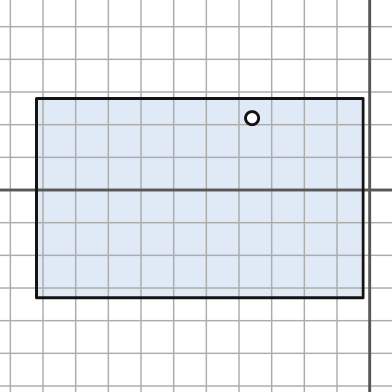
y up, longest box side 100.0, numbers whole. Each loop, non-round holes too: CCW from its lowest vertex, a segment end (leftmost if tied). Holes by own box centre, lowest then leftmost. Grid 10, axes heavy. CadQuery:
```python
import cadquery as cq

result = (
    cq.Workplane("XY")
    .moveTo(-102.0, -33.0)
    .lineTo(-2.0, -33.0)
    .lineTo(-2.0, 28.0)
    .lineTo(-102.0, 28.0)
    .close()
    .moveTo(-36.0, 22.0)
    .circle(2.0)
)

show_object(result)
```